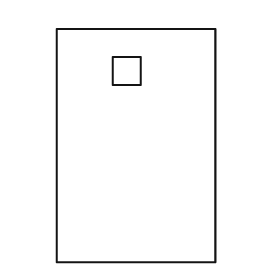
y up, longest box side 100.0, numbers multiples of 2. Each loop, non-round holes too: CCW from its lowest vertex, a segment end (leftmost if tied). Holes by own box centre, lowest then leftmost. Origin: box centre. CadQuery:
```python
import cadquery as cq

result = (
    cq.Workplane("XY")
    .moveTo(-34.0, -50.0)
    .lineTo(34.0, -50.0)
    .lineTo(34.0, 50.0)
    .lineTo(-34.0, 50.0)
    .close()
    .moveTo(-10.0, 26.0)
    .lineTo(2.0, 26.0)
    .lineTo(2.0, 38.0)
    .lineTo(-10.0, 38.0)
    .close()
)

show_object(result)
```